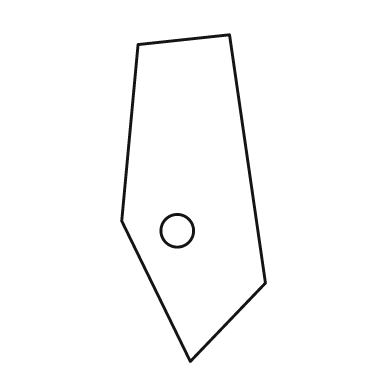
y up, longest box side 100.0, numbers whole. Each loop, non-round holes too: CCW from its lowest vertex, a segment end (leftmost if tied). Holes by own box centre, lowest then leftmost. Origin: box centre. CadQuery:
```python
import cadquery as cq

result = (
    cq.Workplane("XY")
    .moveTo(-1.0, -50.0)
    .lineTo(22.0, -26.0)
    .lineTo(11.0, 50.0)
    .lineTo(-17.0, 47.0)
    .lineTo(-22.0, -7.0)
    .close()
    .moveTo(-5.0, -10.0)
    .circle(5.0)
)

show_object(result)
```